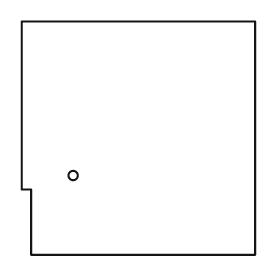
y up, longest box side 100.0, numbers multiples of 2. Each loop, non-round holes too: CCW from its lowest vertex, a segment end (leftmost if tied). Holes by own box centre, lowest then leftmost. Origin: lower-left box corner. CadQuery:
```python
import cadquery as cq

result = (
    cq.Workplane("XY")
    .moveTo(4.0, 0.0)
    .lineTo(100.0, 0.0)
    .lineTo(100.0, 100.0)
    .lineTo(0.0, 100.0)
    .lineTo(0.0, 28.0)
    .lineTo(4.0, 28.0)
    .close()
    .moveTo(22.0, 34.0)
    .circle(2.0)
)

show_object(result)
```